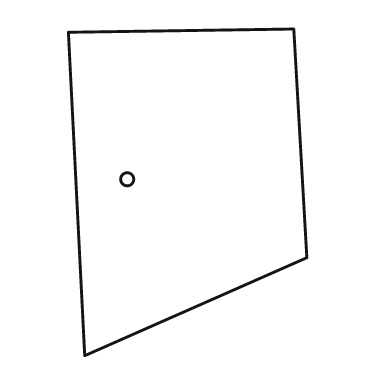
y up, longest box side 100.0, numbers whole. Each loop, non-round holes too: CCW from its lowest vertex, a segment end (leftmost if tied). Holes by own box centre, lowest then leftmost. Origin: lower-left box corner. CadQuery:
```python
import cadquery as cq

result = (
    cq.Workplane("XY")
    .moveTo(5.0, 0.0)
    .lineTo(73.0, 30.0)
    .lineTo(69.0, 100.0)
    .lineTo(0.0, 99.0)
    .close()
    .moveTo(18.0, 54.0)
    .circle(2.0)
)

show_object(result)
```